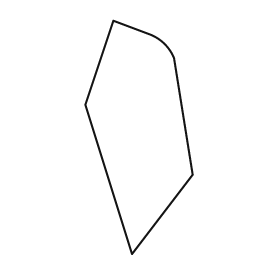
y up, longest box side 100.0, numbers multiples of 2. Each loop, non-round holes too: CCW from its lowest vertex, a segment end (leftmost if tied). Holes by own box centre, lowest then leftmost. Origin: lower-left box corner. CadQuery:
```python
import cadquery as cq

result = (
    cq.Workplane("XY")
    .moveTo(20.0, 0.0)
    .lineTo(46.0, 34.0)
    .lineTo(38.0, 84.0)
    .threePointArc((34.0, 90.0), (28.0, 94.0))
    .lineTo(12.0, 100.0)
    .lineTo(0.0, 64.0)
    .close()
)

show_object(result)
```